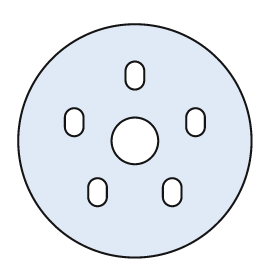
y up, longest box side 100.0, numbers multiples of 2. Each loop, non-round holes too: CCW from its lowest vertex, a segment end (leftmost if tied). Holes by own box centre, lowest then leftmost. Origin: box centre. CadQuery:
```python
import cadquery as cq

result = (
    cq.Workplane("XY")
    .moveTo(0.0, 0.0)
    .circle(50.0)
    .moveTo(-20.0, -24.0)
    .threePointArc((-16.0, -28.0), (-12.0, -24.0))
    .lineTo(-12.0, -20.0)
    .threePointArc((-16.0, -16.0), (-20.0, -20.0))
    .close()
    .moveTo(12.0, -24.0)
    .threePointArc((16.0, -28.0), (20.0, -24.0))
    .lineTo(20.0, -20.0)
    .threePointArc((16.0, -16.0), (12.0, -20.0))
    .close()
    .moveTo(0.0, 0.0)
    .circle(10.0)
    .moveTo(-30.0, 6.0)
    .threePointArc((-26.0, 2.0), (-22.0, 6.0))
    .lineTo(-22.0, 10.0)
    .threePointArc((-26.0, 14.0), (-30.0, 10.0))
    .close()
    .moveTo(22.0, 6.0)
    .threePointArc((26.0, 2.0), (30.0, 6.0))
    .lineTo(30.0, 10.0)
    .threePointArc((26.0, 14.0), (22.0, 10.0))
    .close()
    .moveTo(-4.0, 26.0)
    .threePointArc((0.0, 22.0), (4.0, 26.0))
    .lineTo(4.0, 30.0)
    .threePointArc((0.0, 34.0), (-4.0, 30.0))
    .close()
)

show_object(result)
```